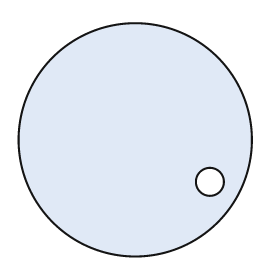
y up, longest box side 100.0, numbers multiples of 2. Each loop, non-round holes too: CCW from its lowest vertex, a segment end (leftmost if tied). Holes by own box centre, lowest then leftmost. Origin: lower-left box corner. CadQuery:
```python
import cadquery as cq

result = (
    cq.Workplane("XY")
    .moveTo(50.0, 50.0)
    .circle(50.0)
    .moveTo(82.0, 32.0)
    .circle(6.0)
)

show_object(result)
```